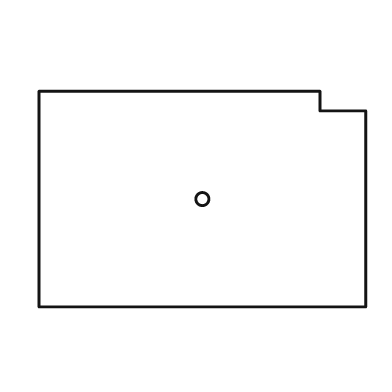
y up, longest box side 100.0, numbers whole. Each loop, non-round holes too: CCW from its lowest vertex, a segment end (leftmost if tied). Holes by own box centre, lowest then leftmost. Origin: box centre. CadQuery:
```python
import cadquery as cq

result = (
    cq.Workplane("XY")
    .moveTo(-50.0, -33.0)
    .lineTo(50.0, -33.0)
    .lineTo(50.0, 27.0)
    .lineTo(36.0, 27.0)
    .lineTo(36.0, 33.0)
    .lineTo(-50.0, 33.0)
    .close()
    .moveTo(0.0, 0.0)
    .circle(2.0)
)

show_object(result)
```